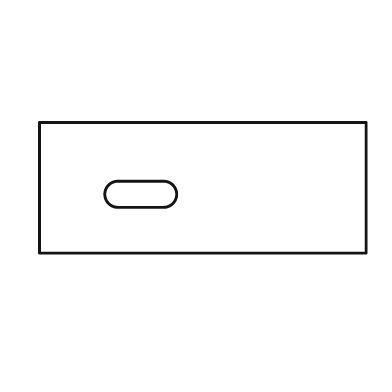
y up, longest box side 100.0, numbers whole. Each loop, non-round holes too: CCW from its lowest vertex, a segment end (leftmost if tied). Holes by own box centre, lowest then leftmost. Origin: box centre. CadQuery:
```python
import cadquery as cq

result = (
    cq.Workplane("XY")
    .moveTo(-50.0, -20.0)
    .lineTo(50.0, -20.0)
    .lineTo(50.0, 20.0)
    .lineTo(-50.0, 20.0)
    .close()
    .moveTo(-26.0, -6.0)
    .lineTo(-12.0, -6.0)
    .threePointArc((-8.0, -2.0), (-12.0, 2.0))
    .lineTo(-26.0, 2.0)
    .threePointArc((-30.0, -2.0), (-26.0, -6.0))
    .close()
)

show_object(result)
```